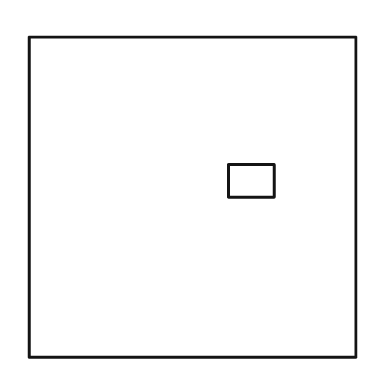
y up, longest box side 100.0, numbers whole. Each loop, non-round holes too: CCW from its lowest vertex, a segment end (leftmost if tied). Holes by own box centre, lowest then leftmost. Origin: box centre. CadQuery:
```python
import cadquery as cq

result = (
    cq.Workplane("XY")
    .moveTo(-50.0, -49.0)
    .lineTo(50.0, -49.0)
    .lineTo(50.0, 49.0)
    .lineTo(-50.0, 49.0)
    .close()
    .moveTo(11.0, 0.0)
    .lineTo(25.0, 0.0)
    .lineTo(25.0, 10.0)
    .lineTo(11.0, 10.0)
    .close()
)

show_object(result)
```